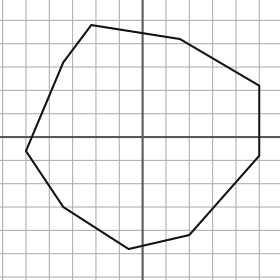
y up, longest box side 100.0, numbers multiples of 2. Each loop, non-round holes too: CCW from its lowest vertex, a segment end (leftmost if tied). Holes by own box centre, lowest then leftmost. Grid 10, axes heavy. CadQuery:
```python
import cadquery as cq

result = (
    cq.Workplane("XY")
    .moveTo(-6.0, -48.0)
    .lineTo(20.0, -42.0)
    .lineTo(50.0, -8.0)
    .lineTo(50.0, 22.0)
    .lineTo(16.0, 42.0)
    .lineTo(-22.0, 48.0)
    .lineTo(-34.0, 32.0)
    .lineTo(-50.0, -6.0)
    .lineTo(-34.0, -30.0)
    .close()
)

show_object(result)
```